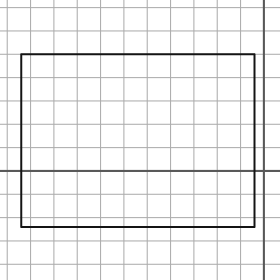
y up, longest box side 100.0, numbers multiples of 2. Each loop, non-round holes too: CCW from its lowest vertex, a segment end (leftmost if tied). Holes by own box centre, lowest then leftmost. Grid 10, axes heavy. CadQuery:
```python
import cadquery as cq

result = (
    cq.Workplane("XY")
    .moveTo(-104.0, -24.0)
    .lineTo(-4.0, -24.0)
    .lineTo(-4.0, 50.0)
    .lineTo(-104.0, 50.0)
    .close()
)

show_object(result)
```